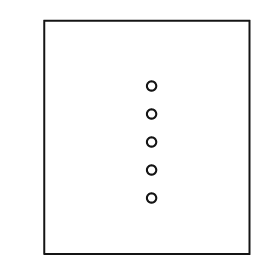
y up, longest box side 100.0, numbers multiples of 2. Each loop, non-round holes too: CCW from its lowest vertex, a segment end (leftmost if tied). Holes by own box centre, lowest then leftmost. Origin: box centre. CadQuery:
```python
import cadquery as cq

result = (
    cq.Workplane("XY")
    .moveTo(-44.0, -50.0)
    .lineTo(44.0, -50.0)
    .lineTo(44.0, 50.0)
    .lineTo(-44.0, 50.0)
    .close()
    .moveTo(2.0, -26.0)
    .circle(2.0)
    .moveTo(2.0, -14.0)
    .circle(2.0)
    .moveTo(2.0, -2.0)
    .circle(2.0)
    .moveTo(2.0, 10.0)
    .circle(2.0)
    .moveTo(2.0, 22.0)
    .circle(2.0)
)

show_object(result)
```